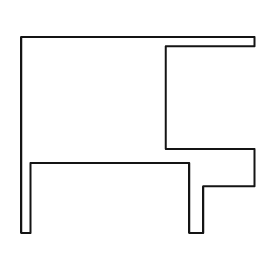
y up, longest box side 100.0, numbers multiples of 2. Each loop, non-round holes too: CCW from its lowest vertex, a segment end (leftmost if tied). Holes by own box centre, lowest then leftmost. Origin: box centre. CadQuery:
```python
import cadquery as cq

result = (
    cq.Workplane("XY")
    .moveTo(-50.0, -42.0)
    .lineTo(-46.0, -42.0)
    .lineTo(-46.0, -12.0)
    .lineTo(22.0, -12.0)
    .lineTo(22.0, -42.0)
    .lineTo(28.0, -42.0)
    .lineTo(28.0, -22.0)
    .lineTo(50.0, -22.0)
    .lineTo(50.0, -6.0)
    .lineTo(12.0, -6.0)
    .lineTo(12.0, 38.0)
    .lineTo(50.0, 38.0)
    .lineTo(50.0, 42.0)
    .lineTo(-50.0, 42.0)
    .close()
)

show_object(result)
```